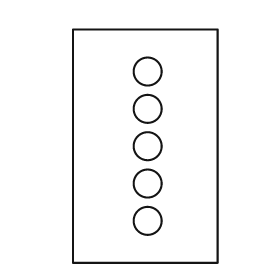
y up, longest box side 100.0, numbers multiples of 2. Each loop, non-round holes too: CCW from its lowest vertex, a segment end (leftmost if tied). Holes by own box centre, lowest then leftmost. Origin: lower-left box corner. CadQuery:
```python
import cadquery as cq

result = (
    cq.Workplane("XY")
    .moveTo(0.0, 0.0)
    .lineTo(62.0, 0.0)
    .lineTo(62.0, 100.0)
    .lineTo(0.0, 100.0)
    .close()
    .moveTo(32.0, 18.0)
    .circle(6.0)
    .moveTo(32.0, 34.0)
    .circle(6.0)
    .moveTo(32.0, 50.0)
    .circle(6.0)
    .moveTo(32.0, 66.0)
    .circle(6.0)
    .moveTo(32.0, 82.0)
    .circle(6.0)
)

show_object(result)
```